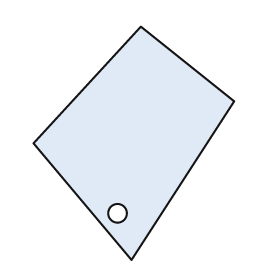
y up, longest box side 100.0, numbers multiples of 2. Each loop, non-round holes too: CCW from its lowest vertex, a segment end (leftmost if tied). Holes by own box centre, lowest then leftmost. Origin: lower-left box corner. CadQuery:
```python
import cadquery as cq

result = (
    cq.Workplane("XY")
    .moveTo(42.0, 0.0)
    .lineTo(86.0, 68.0)
    .lineTo(46.0, 100.0)
    .lineTo(0.0, 50.0)
    .close()
    .moveTo(36.0, 20.0)
    .circle(4.0)
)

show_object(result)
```